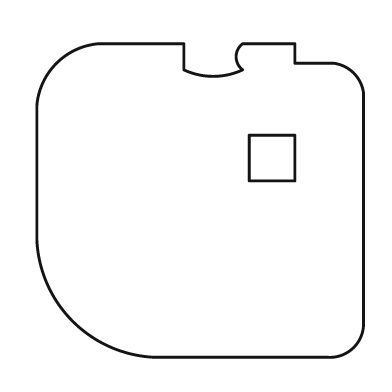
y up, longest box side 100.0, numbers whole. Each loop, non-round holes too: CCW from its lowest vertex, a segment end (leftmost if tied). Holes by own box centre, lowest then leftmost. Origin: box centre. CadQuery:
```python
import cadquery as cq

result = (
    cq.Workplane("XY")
    .moveTo(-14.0, -48.0)
    .lineTo(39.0, -48.0)
    .threePointArc((47.0, -45.0), (50.0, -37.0))
    .lineTo(50.0, 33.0)
    .threePointArc((47.0, 39.0), (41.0, 42.0))
    .lineTo(29.0, 42.0)
    .lineTo(29.0, 48.0)
    .lineTo(13.0, 48.0)
    .threePointArc((11.0, 44.0), (13.0, 40.0))
    .threePointArc((4.0, 38.0), (-5.0, 40.0))
    .lineTo(-5.0, 48.0)
    .lineTo(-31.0, 48.0)
    .threePointArc((-44.0, 42.0), (-50.0, 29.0))
    .lineTo(-50.0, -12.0)
    .threePointArc((-39.0, -37.0), (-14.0, -48.0))
    .close()
    .moveTo(15.0, 6.0)
    .lineTo(29.0, 6.0)
    .lineTo(29.0, 20.0)
    .lineTo(15.0, 20.0)
    .close()
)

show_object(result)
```